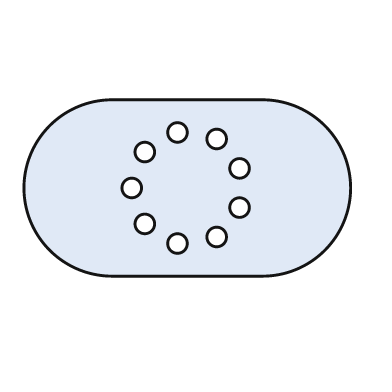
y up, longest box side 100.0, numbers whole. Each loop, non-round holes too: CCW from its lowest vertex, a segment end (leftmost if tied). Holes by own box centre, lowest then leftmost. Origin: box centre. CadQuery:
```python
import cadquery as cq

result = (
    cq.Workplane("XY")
    .moveTo(-23.0, -27.0)
    .lineTo(23.0, -27.0)
    .threePointArc((50.0, 0.0), (23.0, 27.0))
    .lineTo(-23.0, 27.0)
    .threePointArc((-50.0, 0.0), (-23.0, -27.0))
    .close()
    .moveTo(-3.0, -17.0)
    .circle(3.0)
    .moveTo(9.0, -15.0)
    .circle(3.0)
    .moveTo(-13.0, -11.0)
    .circle(3.0)
    .moveTo(16.0, -6.0)
    .circle(3.0)
    .moveTo(-17.0, 0.0)
    .circle(3.0)
    .moveTo(16.0, 6.0)
    .circle(3.0)
    .moveTo(-13.0, 11.0)
    .circle(3.0)
    .moveTo(9.0, 15.0)
    .circle(3.0)
    .moveTo(-3.0, 17.0)
    .circle(3.0)
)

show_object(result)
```